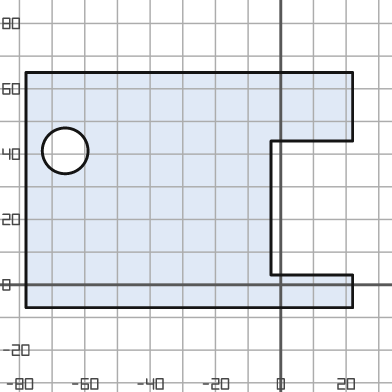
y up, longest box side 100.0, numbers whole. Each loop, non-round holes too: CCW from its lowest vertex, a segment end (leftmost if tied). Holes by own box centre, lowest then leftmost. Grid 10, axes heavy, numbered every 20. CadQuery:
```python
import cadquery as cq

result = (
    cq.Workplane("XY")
    .moveTo(-78.0, -7.0)
    .lineTo(22.0, -7.0)
    .lineTo(22.0, 3.0)
    .lineTo(-3.0, 3.0)
    .lineTo(-3.0, 44.0)
    .lineTo(22.0, 44.0)
    .lineTo(22.0, 65.0)
    .lineTo(-78.0, 65.0)
    .close()
    .moveTo(-66.0, 41.0)
    .circle(7.0)
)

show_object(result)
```